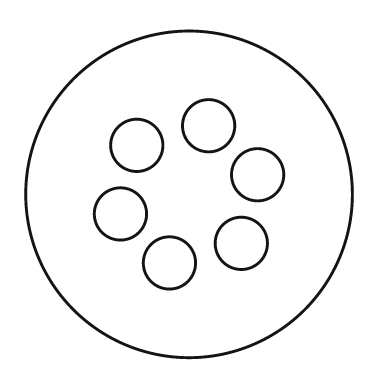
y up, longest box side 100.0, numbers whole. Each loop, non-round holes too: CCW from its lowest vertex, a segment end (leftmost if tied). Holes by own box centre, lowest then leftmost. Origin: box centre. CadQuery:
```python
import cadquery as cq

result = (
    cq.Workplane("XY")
    .moveTo(0.0, 0.0)
    .circle(50.0)
    .moveTo(-6.0, -21.0)
    .circle(8.0)
    .moveTo(16.0, -15.0)
    .circle(8.0)
    .moveTo(-21.0, -6.0)
    .circle(8.0)
    .moveTo(21.0, 6.0)
    .circle(8.0)
    .moveTo(-16.0, 15.0)
    .circle(8.0)
    .moveTo(6.0, 21.0)
    .circle(8.0)
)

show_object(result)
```